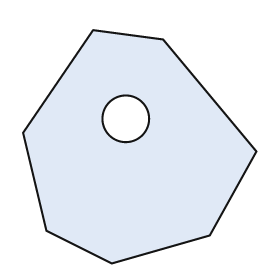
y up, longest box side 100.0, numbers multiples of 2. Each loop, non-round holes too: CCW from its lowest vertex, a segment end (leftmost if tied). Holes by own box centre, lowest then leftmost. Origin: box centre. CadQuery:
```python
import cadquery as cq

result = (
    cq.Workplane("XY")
    .moveTo(-12.0, -50.0)
    .lineTo(30.0, -38.0)
    .lineTo(50.0, -2.0)
    .lineTo(10.0, 46.0)
    .lineTo(-20.0, 50.0)
    .lineTo(-50.0, 6.0)
    .lineTo(-40.0, -36.0)
    .close()
    .moveTo(-6.0, 12.0)
    .circle(10.0)
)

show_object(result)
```